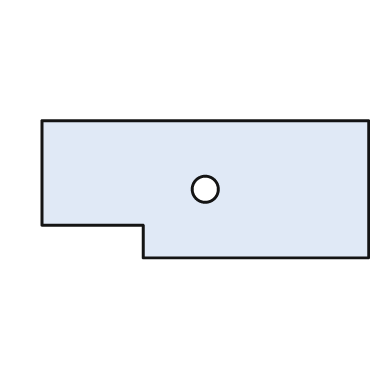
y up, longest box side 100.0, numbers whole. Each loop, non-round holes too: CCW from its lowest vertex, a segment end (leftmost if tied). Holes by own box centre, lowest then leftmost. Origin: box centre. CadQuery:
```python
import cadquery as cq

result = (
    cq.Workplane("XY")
    .moveTo(-19.0, -21.0)
    .lineTo(50.0, -21.0)
    .lineTo(50.0, 21.0)
    .lineTo(-50.0, 21.0)
    .lineTo(-50.0, -11.0)
    .lineTo(-19.0, -11.0)
    .close()
    .moveTo(0.0, 0.0)
    .circle(4.0)
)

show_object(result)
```